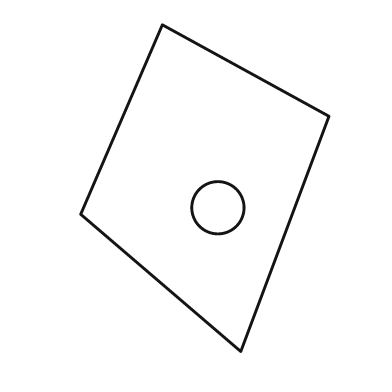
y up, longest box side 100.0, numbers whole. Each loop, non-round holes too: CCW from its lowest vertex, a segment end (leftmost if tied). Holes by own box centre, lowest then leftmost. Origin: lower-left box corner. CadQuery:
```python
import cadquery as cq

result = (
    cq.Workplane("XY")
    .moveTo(49.0, 0.0)
    .lineTo(76.0, 72.0)
    .lineTo(25.0, 100.0)
    .lineTo(0.0, 42.0)
    .close()
    .moveTo(42.0, 44.0)
    .circle(8.0)
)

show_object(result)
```